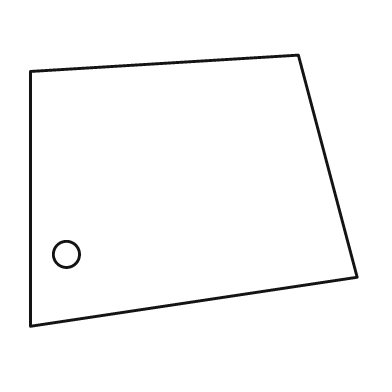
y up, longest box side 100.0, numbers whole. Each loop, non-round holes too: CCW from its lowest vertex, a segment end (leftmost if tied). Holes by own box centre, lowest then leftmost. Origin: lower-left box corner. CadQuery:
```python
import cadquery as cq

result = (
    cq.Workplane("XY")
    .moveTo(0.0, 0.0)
    .lineTo(100.0, 15.0)
    .lineTo(82.0, 83.0)
    .lineTo(0.0, 78.0)
    .close()
    .moveTo(11.0, 22.0)
    .circle(4.0)
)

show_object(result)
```